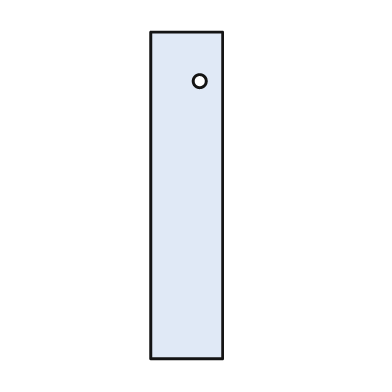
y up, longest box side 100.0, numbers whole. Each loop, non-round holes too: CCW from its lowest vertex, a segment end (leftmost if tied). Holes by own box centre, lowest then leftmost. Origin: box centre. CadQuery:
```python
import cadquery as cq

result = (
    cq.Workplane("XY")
    .moveTo(-11.0, -50.0)
    .lineTo(11.0, -50.0)
    .lineTo(11.0, 50.0)
    .lineTo(-11.0, 50.0)
    .close()
    .moveTo(4.0, 35.0)
    .circle(2.0)
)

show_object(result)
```